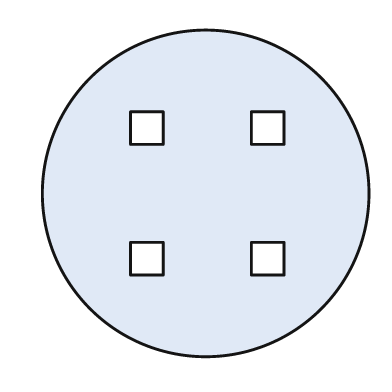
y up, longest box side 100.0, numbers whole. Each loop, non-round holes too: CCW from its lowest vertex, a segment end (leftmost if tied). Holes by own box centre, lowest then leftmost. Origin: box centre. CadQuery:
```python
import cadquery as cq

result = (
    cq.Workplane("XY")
    .moveTo(0.0, 0.0)
    .circle(50.0)
    .moveTo(-23.0, -25.0)
    .lineTo(-13.0, -25.0)
    .lineTo(-13.0, -15.0)
    .lineTo(-23.0, -15.0)
    .close()
    .moveTo(14.0, -25.0)
    .lineTo(24.0, -25.0)
    .lineTo(24.0, -15.0)
    .lineTo(14.0, -15.0)
    .close()
    .moveTo(-23.0, 15.0)
    .lineTo(-13.0, 15.0)
    .lineTo(-13.0, 25.0)
    .lineTo(-23.0, 25.0)
    .close()
    .moveTo(14.0, 15.0)
    .lineTo(24.0, 15.0)
    .lineTo(24.0, 25.0)
    .lineTo(14.0, 25.0)
    .close()
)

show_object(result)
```